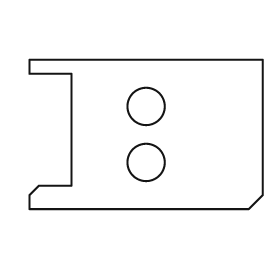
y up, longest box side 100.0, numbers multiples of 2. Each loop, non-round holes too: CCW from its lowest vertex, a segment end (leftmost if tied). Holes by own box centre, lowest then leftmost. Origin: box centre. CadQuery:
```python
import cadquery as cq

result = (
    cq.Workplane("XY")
    .moveTo(-50.0, -32.0)
    .lineTo(44.0, -32.0)
    .lineTo(50.0, -26.0)
    .lineTo(50.0, 32.0)
    .lineTo(-50.0, 32.0)
    .lineTo(-50.0, 26.0)
    .lineTo(-32.0, 26.0)
    .lineTo(-32.0, -22.0)
    .lineTo(-46.0, -22.0)
    .lineTo(-50.0, -26.0)
    .close()
    .moveTo(0.0, -12.0)
    .circle(8.0)
    .moveTo(0.0, 12.0)
    .circle(8.0)
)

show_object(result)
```